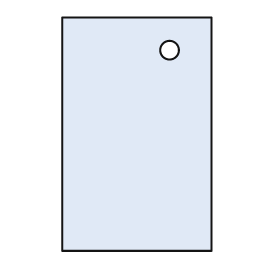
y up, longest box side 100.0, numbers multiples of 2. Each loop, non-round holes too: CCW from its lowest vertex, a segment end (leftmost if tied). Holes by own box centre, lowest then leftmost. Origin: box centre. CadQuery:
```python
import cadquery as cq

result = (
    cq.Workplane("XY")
    .moveTo(-32.0, -50.0)
    .lineTo(32.0, -50.0)
    .lineTo(32.0, 50.0)
    .lineTo(-32.0, 50.0)
    .close()
    .moveTo(14.0, 36.0)
    .circle(4.0)
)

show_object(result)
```